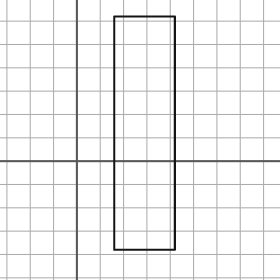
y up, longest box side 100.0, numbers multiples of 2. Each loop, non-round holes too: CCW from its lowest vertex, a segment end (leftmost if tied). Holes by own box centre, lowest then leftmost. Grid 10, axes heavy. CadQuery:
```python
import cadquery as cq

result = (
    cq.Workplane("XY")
    .moveTo(16.0, -38.0)
    .lineTo(42.0, -38.0)
    .lineTo(42.0, 62.0)
    .lineTo(16.0, 62.0)
    .close()
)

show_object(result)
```